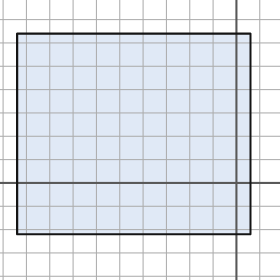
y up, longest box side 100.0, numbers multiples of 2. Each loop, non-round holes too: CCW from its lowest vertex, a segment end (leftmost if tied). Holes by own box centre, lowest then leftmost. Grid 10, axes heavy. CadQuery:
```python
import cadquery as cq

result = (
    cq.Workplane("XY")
    .moveTo(-94.0, -22.0)
    .lineTo(6.0, -22.0)
    .lineTo(6.0, 64.0)
    .lineTo(-94.0, 64.0)
    .close()
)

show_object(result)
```